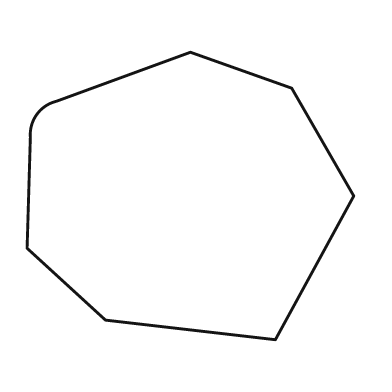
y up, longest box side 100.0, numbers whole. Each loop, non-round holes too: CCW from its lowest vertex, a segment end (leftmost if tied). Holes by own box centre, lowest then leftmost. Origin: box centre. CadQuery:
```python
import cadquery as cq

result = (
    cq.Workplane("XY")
    .moveTo(26.0, -44.0)
    .lineTo(50.0, 0.0)
    .lineTo(31.0, 33.0)
    .lineTo(0.0, 44.0)
    .lineTo(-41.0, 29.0)
    .threePointArc((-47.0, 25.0), (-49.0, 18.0))
    .lineTo(-50.0, -16.0)
    .lineTo(-26.0, -38.0)
    .close()
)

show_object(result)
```